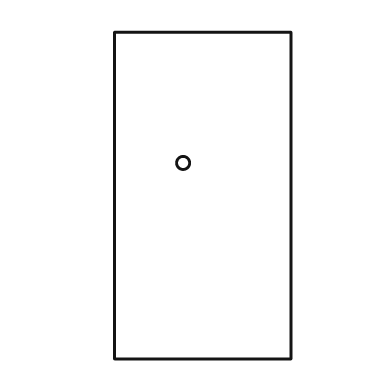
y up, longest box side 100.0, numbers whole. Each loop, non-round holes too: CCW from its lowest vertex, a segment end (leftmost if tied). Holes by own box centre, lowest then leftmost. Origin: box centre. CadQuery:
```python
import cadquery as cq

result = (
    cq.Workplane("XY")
    .moveTo(-27.0, -50.0)
    .lineTo(27.0, -50.0)
    .lineTo(27.0, 50.0)
    .lineTo(-27.0, 50.0)
    .close()
    .moveTo(-6.0, 10.0)
    .circle(2.0)
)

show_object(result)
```